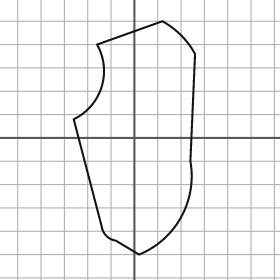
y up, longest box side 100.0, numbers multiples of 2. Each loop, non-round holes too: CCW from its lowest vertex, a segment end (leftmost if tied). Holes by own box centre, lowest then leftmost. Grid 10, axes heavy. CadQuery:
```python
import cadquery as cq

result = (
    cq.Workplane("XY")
    .moveTo(2.0, -50.0)
    .threePointArc((20.0, -34.0), (24.0, -10.0))
    .lineTo(26.0, 36.0)
    .threePointArc((20.0, 44.0), (12.0, 50.0))
    .lineTo(-16.0, 40.0)
    .threePointArc((-14.0, 22.0), (-26.0, 8.0))
    .lineTo(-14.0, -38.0)
    .threePointArc((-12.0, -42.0), (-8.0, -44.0))
    .close()
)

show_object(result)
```